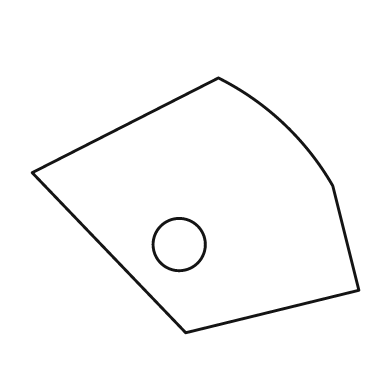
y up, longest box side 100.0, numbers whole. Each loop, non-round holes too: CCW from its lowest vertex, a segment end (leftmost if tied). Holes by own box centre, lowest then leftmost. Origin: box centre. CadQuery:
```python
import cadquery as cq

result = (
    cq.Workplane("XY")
    .moveTo(-3.0, -39.0)
    .lineTo(50.0, -26.0)
    .lineTo(42.0, 6.0)
    .threePointArc((27.0, 25.0), (7.0, 39.0))
    .lineTo(-50.0, 10.0)
    .close()
    .moveTo(-5.0, -12.0)
    .circle(8.0)
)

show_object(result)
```